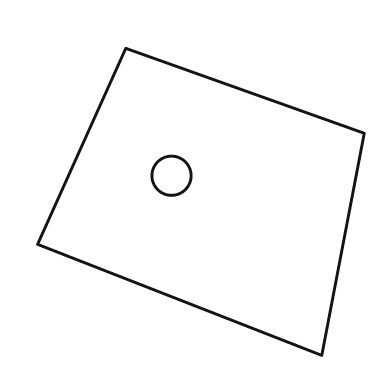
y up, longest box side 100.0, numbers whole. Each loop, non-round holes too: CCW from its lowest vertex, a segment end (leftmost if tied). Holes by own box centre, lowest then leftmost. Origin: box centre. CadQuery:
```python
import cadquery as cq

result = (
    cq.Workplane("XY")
    .moveTo(37.0, -47.0)
    .lineTo(50.0, 21.0)
    .lineTo(-23.0, 47.0)
    .lineTo(-50.0, -13.0)
    .close()
    .moveTo(-9.0, 8.0)
    .circle(6.0)
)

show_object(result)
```